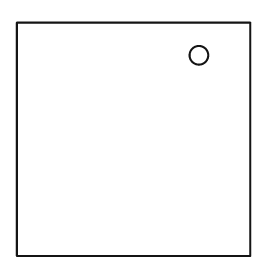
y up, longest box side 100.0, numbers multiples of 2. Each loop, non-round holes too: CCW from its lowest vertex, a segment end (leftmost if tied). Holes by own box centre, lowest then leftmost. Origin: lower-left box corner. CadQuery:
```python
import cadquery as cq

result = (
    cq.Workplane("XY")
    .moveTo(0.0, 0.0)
    .lineTo(100.0, 0.0)
    .lineTo(100.0, 100.0)
    .lineTo(0.0, 100.0)
    .close()
    .moveTo(78.0, 86.0)
    .circle(4.0)
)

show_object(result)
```